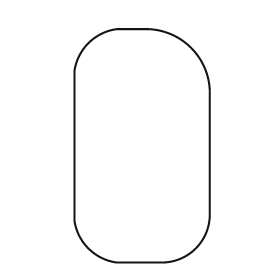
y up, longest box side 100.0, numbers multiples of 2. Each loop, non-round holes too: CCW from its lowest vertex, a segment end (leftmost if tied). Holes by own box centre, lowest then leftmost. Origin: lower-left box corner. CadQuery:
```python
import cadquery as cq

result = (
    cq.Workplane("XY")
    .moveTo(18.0, 0.0)
    .lineTo(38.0, 0.0)
    .threePointArc((52.0, 6.0), (58.0, 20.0))
    .lineTo(58.0, 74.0)
    .threePointArc((50.0, 92.0), (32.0, 100.0))
    .lineTo(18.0, 100.0)
    .threePointArc((6.0, 94.0), (0.0, 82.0))
    .lineTo(0.0, 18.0)
    .threePointArc((6.0, 6.0), (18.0, 0.0))
    .close()
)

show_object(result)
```